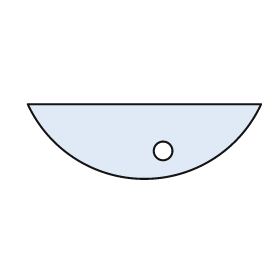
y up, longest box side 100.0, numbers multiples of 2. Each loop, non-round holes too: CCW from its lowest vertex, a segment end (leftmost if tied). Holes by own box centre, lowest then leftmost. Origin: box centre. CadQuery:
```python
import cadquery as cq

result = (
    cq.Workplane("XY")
    .moveTo(-50.0, 16.0)
    .threePointArc((0.0, -16.0), (50.0, 16.0))
    .close()
    .moveTo(8.0, -4.0)
    .circle(4.0)
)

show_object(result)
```